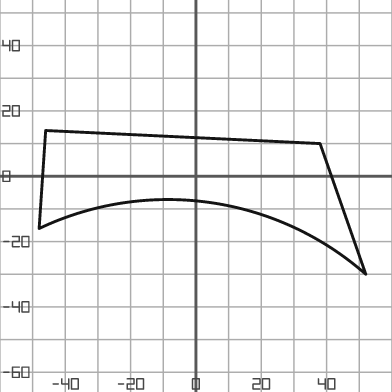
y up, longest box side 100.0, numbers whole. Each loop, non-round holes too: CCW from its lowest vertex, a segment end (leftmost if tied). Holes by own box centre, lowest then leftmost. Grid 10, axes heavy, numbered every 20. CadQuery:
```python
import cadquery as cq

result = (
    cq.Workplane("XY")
    .moveTo(52.0, -30.0)
    .lineTo(38.0, 10.0)
    .lineTo(-46.0, 14.0)
    .lineTo(-48.0, -16.0)
    .threePointArc((4.0, -8.0), (52.0, -30.0))
    .close()
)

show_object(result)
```